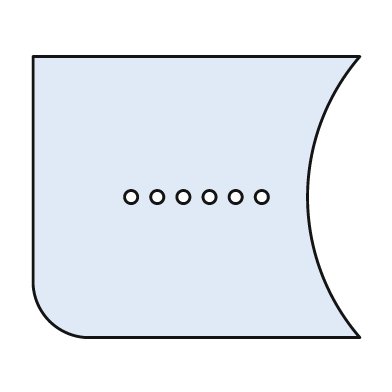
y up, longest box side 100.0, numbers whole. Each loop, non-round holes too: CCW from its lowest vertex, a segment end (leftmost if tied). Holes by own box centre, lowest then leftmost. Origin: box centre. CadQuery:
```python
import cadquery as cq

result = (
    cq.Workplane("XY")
    .moveTo(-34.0, -43.0)
    .lineTo(50.0, -43.0)
    .threePointArc((34.0, 0.0), (50.0, 43.0))
    .lineTo(-50.0, 43.0)
    .lineTo(-50.0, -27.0)
    .threePointArc((-45.0, -38.0), (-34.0, -43.0))
    .close()
    .moveTo(-20.0, 0.0)
    .circle(2.0)
    .moveTo(-12.0, 0.0)
    .circle(2.0)
    .moveTo(-4.0, 0.0)
    .circle(2.0)
    .moveTo(4.0, 0.0)
    .circle(2.0)
    .moveTo(12.0, 0.0)
    .circle(2.0)
    .moveTo(20.0, 0.0)
    .circle(2.0)
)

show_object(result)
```